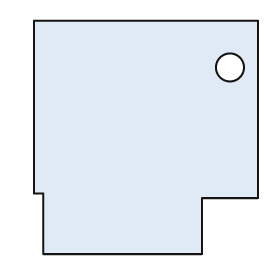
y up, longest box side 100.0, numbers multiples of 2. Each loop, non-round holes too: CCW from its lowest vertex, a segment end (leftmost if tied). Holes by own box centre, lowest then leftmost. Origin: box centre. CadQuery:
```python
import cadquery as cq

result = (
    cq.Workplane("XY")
    .moveTo(-44.0, -50.0)
    .lineTo(24.0, -50.0)
    .lineTo(24.0, -26.0)
    .lineTo(48.0, -26.0)
    .lineTo(48.0, 50.0)
    .lineTo(-48.0, 50.0)
    .lineTo(-48.0, -24.0)
    .lineTo(-44.0, -24.0)
    .close()
    .moveTo(36.0, 30.0)
    .circle(6.0)
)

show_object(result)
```